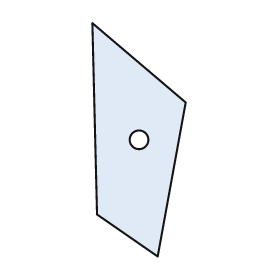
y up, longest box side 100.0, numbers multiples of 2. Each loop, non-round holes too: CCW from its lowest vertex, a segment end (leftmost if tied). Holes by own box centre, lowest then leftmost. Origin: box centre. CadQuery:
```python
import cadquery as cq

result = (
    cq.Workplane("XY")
    .moveTo(8.0, -50.0)
    .lineTo(20.0, 16.0)
    .lineTo(-20.0, 50.0)
    .lineTo(-18.0, -32.0)
    .close()
    .moveTo(0.0, 0.0)
    .circle(4.0)
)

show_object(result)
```